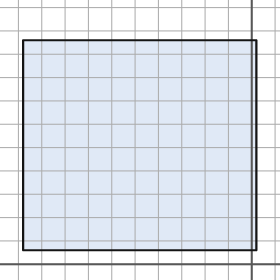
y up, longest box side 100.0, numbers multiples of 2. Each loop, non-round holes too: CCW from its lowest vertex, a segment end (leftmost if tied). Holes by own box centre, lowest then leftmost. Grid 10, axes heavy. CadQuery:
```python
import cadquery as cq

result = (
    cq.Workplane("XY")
    .moveTo(-98.0, 6.0)
    .lineTo(2.0, 6.0)
    .lineTo(2.0, 96.0)
    .lineTo(-98.0, 96.0)
    .close()
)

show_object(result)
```